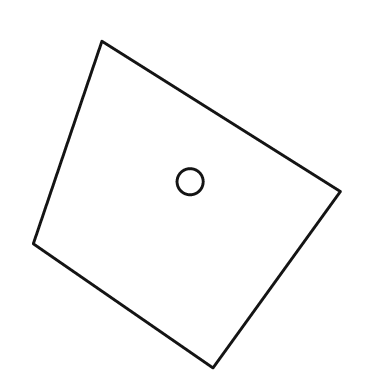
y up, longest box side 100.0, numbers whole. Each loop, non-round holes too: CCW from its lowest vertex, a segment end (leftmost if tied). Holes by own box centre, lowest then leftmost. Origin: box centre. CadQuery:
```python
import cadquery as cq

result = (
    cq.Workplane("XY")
    .moveTo(8.0, -50.0)
    .lineTo(47.0, 4.0)
    .lineTo(-26.0, 50.0)
    .lineTo(-47.0, -12.0)
    .close()
    .moveTo(1.0, 7.0)
    .circle(4.0)
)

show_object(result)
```